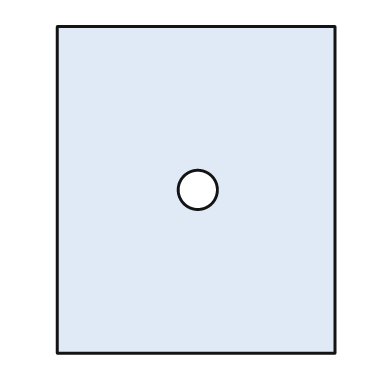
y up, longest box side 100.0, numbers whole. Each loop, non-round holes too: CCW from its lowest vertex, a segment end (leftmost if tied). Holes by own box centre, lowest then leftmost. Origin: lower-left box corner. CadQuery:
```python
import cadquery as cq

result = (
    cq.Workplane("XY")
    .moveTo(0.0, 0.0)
    .lineTo(85.0, 0.0)
    .lineTo(85.0, 100.0)
    .lineTo(0.0, 100.0)
    .close()
    .moveTo(43.0, 50.0)
    .circle(6.0)
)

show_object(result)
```